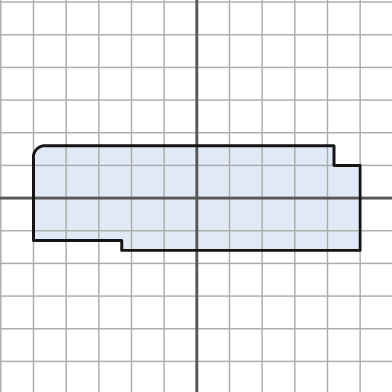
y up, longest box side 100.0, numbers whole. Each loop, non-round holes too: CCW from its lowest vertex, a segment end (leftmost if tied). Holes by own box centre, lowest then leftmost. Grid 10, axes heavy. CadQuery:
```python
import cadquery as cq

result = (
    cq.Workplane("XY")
    .moveTo(-23.0, -16.0)
    .lineTo(50.0, -16.0)
    .lineTo(50.0, 10.0)
    .lineTo(42.0, 10.0)
    .lineTo(42.0, 16.0)
    .lineTo(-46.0, 16.0)
    .threePointArc((-49.0, 15.0), (-50.0, 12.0))
    .lineTo(-50.0, -13.0)
    .lineTo(-23.0, -13.0)
    .close()
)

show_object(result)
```